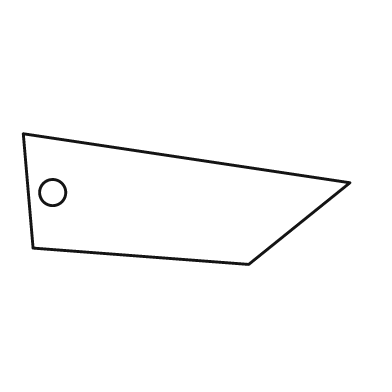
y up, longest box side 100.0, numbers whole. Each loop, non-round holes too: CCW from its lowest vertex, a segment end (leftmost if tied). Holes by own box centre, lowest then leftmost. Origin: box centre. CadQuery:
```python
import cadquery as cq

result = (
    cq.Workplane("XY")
    .moveTo(19.0, -20.0)
    .lineTo(50.0, 5.0)
    .lineTo(-50.0, 20.0)
    .lineTo(-47.0, -15.0)
    .close()
    .moveTo(-41.0, 2.0)
    .circle(4.0)
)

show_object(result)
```